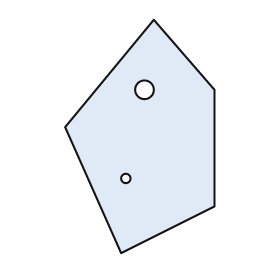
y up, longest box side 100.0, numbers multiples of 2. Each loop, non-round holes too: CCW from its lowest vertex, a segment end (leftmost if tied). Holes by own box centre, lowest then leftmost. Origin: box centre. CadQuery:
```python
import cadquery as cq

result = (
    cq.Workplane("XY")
    .moveTo(-8.0, -50.0)
    .lineTo(32.0, -30.0)
    .lineTo(32.0, 20.0)
    .lineTo(6.0, 50.0)
    .lineTo(-32.0, 4.0)
    .close()
    .moveTo(-6.0, -18.0)
    .circle(2.0)
    .moveTo(2.0, 20.0)
    .circle(4.0)
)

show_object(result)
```